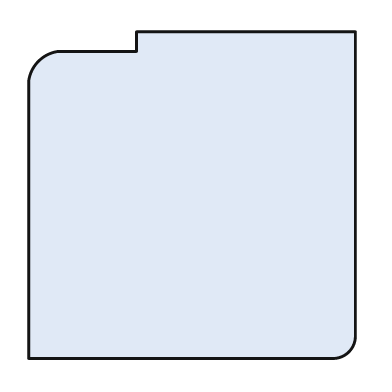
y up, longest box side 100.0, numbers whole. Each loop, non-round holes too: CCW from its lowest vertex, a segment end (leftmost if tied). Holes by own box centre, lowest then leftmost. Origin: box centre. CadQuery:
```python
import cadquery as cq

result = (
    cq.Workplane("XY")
    .moveTo(-50.0, -50.0)
    .lineTo(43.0, -50.0)
    .threePointArc((48.0, -48.0), (50.0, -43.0))
    .lineTo(50.0, 50.0)
    .lineTo(-17.0, 50.0)
    .lineTo(-17.0, 44.0)
    .lineTo(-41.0, 44.0)
    .threePointArc((-47.0, 41.0), (-50.0, 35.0))
    .close()
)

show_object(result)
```